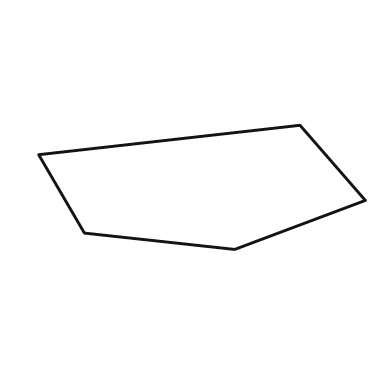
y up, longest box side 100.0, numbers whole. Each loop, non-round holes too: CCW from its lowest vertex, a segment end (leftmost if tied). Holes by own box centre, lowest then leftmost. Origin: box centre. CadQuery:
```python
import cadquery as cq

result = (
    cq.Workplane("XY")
    .moveTo(10.0, -19.0)
    .lineTo(50.0, -4.0)
    .lineTo(30.0, 19.0)
    .lineTo(-50.0, 10.0)
    .lineTo(-36.0, -14.0)
    .close()
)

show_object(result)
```